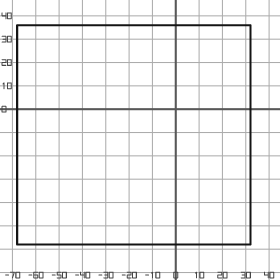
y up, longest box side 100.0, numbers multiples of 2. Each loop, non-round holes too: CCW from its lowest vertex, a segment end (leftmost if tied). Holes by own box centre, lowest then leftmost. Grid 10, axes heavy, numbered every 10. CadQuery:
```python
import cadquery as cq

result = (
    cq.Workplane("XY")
    .moveTo(-68.0, -58.0)
    .lineTo(32.0, -58.0)
    .lineTo(32.0, 36.0)
    .lineTo(-68.0, 36.0)
    .close()
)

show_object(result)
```